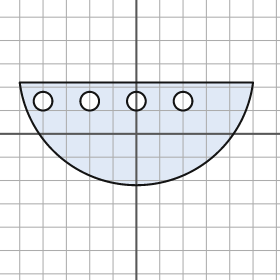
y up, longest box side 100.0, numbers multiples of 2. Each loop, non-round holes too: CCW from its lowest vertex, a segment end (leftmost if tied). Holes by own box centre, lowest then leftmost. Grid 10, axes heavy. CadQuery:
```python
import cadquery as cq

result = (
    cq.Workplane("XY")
    .moveTo(-50.0, 22.0)
    .threePointArc((0.0, -22.0), (50.0, 22.0))
    .close()
    .moveTo(-40.0, 14.0)
    .circle(4.0)
    .moveTo(-20.0, 14.0)
    .circle(4.0)
    .moveTo(0.0, 14.0)
    .circle(4.0)
    .moveTo(20.0, 14.0)
    .circle(4.0)
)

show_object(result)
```